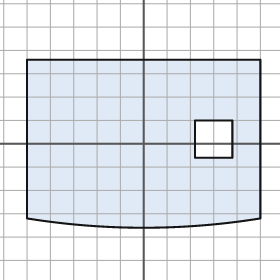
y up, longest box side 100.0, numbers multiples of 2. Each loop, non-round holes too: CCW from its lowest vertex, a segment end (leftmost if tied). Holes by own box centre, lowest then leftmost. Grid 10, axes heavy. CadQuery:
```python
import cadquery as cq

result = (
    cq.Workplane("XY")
    .moveTo(-50.0, -32.0)
    .threePointArc((0.0, -36.0), (50.0, -32.0))
    .lineTo(50.0, 36.0)
    .lineTo(-50.0, 36.0)
    .close()
    .moveTo(22.0, -6.0)
    .lineTo(38.0, -6.0)
    .lineTo(38.0, 10.0)
    .lineTo(22.0, 10.0)
    .close()
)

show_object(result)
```